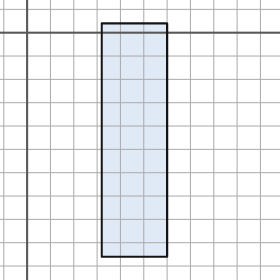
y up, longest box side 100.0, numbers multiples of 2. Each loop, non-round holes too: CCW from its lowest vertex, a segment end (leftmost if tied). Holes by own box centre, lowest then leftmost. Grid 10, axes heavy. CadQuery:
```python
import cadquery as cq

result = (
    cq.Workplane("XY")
    .moveTo(32.0, -96.0)
    .lineTo(60.0, -96.0)
    .lineTo(60.0, 4.0)
    .lineTo(32.0, 4.0)
    .close()
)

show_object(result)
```